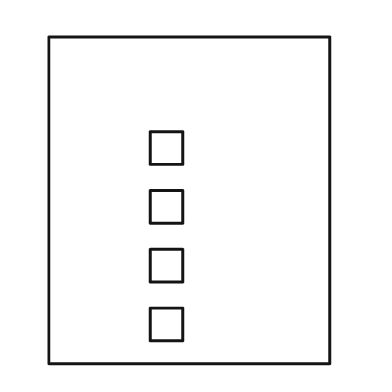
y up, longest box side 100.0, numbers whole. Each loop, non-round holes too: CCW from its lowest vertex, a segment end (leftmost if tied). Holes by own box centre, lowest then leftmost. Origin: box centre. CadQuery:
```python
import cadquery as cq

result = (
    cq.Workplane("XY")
    .moveTo(-43.0, -50.0)
    .lineTo(43.0, -50.0)
    .lineTo(43.0, 50.0)
    .lineTo(-43.0, 50.0)
    .close()
    .moveTo(-12.0, -43.0)
    .lineTo(-2.0, -43.0)
    .lineTo(-2.0, -33.0)
    .lineTo(-12.0, -33.0)
    .close()
    .moveTo(-12.0, -25.0)
    .lineTo(-2.0, -25.0)
    .lineTo(-2.0, -15.0)
    .lineTo(-12.0, -15.0)
    .close()
    .moveTo(-12.0, -7.0)
    .lineTo(-2.0, -7.0)
    .lineTo(-2.0, 3.0)
    .lineTo(-12.0, 3.0)
    .close()
    .moveTo(-12.0, 11.0)
    .lineTo(-2.0, 11.0)
    .lineTo(-2.0, 21.0)
    .lineTo(-12.0, 21.0)
    .close()
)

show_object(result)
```